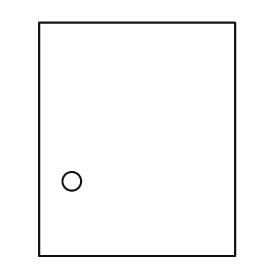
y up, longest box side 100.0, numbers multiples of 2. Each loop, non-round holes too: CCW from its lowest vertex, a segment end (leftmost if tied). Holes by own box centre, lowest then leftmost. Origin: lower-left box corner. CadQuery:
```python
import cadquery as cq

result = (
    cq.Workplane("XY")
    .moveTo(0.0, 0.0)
    .lineTo(84.0, 0.0)
    .lineTo(84.0, 100.0)
    .lineTo(0.0, 100.0)
    .close()
    .moveTo(14.0, 32.0)
    .circle(4.0)
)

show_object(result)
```